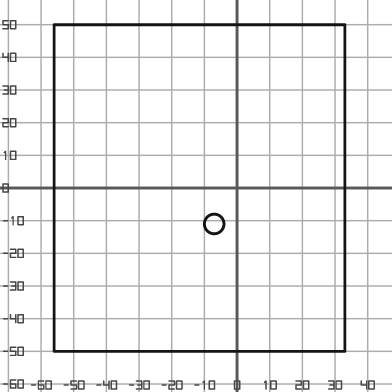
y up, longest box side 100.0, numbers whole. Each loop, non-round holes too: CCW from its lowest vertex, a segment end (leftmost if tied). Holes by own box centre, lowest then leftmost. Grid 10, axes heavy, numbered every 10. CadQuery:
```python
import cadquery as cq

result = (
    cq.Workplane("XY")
    .moveTo(-56.0, -50.0)
    .lineTo(33.0, -50.0)
    .lineTo(33.0, 50.0)
    .lineTo(-56.0, 50.0)
    .close()
    .moveTo(-7.0, -11.0)
    .circle(3.0)
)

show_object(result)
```